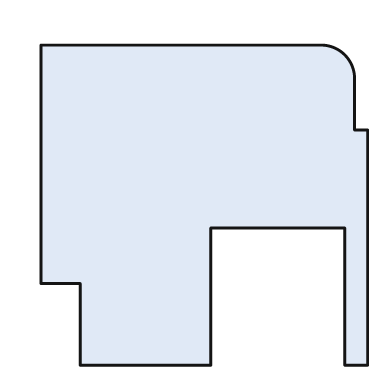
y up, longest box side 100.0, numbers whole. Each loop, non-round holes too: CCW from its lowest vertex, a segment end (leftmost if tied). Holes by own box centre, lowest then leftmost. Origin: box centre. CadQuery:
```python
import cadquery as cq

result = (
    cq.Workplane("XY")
    .moveTo(-38.0, -49.0)
    .lineTo(2.0, -49.0)
    .lineTo(2.0, -7.0)
    .lineTo(43.0, -7.0)
    .lineTo(43.0, -49.0)
    .lineTo(50.0, -49.0)
    .lineTo(50.0, 23.0)
    .lineTo(46.0, 23.0)
    .lineTo(46.0, 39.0)
    .threePointArc((43.0, 46.0), (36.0, 49.0))
    .lineTo(-50.0, 49.0)
    .lineTo(-50.0, -24.0)
    .lineTo(-38.0, -24.0)
    .close()
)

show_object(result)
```